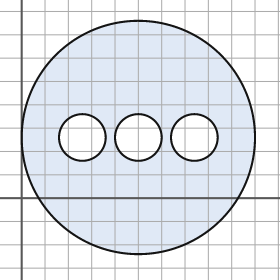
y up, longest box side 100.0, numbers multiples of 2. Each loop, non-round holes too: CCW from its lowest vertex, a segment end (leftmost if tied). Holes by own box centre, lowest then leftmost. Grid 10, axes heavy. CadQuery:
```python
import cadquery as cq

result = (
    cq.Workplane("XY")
    .moveTo(50.0, 26.0)
    .circle(50.0)
    .moveTo(26.0, 26.0)
    .circle(10.0)
    .moveTo(50.0, 26.0)
    .circle(10.0)
    .moveTo(74.0, 26.0)
    .circle(10.0)
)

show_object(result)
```